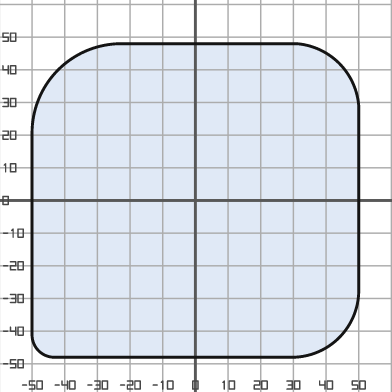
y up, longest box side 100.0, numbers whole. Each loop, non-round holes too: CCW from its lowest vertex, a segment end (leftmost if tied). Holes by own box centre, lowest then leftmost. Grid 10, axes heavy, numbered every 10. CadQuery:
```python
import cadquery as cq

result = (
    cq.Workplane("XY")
    .moveTo(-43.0, -48.0)
    .lineTo(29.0, -48.0)
    .threePointArc((44.0, -42.0), (50.0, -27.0))
    .lineTo(50.0, 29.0)
    .threePointArc((44.0, 42.0), (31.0, 48.0))
    .lineTo(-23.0, 48.0)
    .threePointArc((-42.0, 40.0), (-50.0, 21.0))
    .lineTo(-50.0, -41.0)
    .threePointArc((-48.0, -46.0), (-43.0, -48.0))
    .close()
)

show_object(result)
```